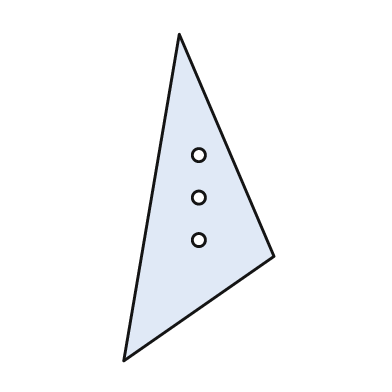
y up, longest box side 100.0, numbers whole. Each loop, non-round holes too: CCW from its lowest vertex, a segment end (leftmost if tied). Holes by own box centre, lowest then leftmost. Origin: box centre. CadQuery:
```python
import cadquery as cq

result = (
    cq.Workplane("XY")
    .moveTo(-23.0, -50.0)
    .lineTo(23.0, -18.0)
    .lineTo(-6.0, 50.0)
    .close()
    .moveTo(0.0, -13.0)
    .circle(2.0)
    .moveTo(0.0, 0.0)
    .circle(2.0)
    .moveTo(0.0, 13.0)
    .circle(2.0)
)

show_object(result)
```